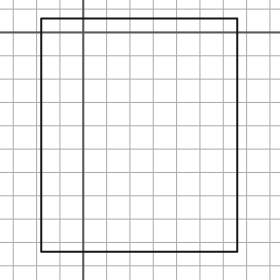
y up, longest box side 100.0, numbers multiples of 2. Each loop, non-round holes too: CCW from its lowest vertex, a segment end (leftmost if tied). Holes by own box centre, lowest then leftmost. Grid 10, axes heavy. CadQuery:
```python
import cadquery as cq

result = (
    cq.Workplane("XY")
    .moveTo(-18.0, -94.0)
    .lineTo(66.0, -94.0)
    .lineTo(66.0, 6.0)
    .lineTo(-18.0, 6.0)
    .close()
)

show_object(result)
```